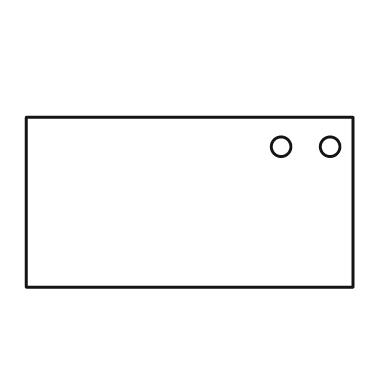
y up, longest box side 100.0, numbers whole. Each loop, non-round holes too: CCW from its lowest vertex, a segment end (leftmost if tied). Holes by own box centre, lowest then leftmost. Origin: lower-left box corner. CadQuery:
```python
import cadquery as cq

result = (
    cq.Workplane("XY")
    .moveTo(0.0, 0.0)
    .lineTo(100.0, 0.0)
    .lineTo(100.0, 52.0)
    .lineTo(0.0, 52.0)
    .close()
    .moveTo(78.0, 43.0)
    .circle(3.0)
    .moveTo(93.0, 43.0)
    .circle(3.0)
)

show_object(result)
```